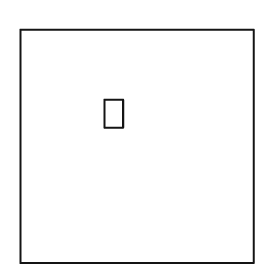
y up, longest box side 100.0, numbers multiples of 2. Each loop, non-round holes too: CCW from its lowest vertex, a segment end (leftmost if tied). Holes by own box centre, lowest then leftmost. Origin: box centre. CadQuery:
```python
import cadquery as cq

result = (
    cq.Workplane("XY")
    .moveTo(-50.0, -50.0)
    .lineTo(50.0, -50.0)
    .lineTo(50.0, 50.0)
    .lineTo(-50.0, 50.0)
    .close()
    .moveTo(-14.0, 8.0)
    .lineTo(-6.0, 8.0)
    .lineTo(-6.0, 20.0)
    .lineTo(-14.0, 20.0)
    .close()
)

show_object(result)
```